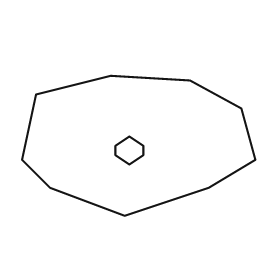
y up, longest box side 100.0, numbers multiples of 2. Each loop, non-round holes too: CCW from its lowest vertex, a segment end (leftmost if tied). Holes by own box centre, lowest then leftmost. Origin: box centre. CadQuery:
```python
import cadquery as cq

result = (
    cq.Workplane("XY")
    .moveTo(-6.0, -30.0)
    .lineTo(30.0, -18.0)
    .lineTo(50.0, -6.0)
    .lineTo(44.0, 16.0)
    .lineTo(22.0, 28.0)
    .lineTo(-12.0, 30.0)
    .lineTo(-44.0, 22.0)
    .lineTo(-50.0, -6.0)
    .lineTo(-38.0, -18.0)
    .close()
    .moveTo(-4.0, -8.0)
    .lineTo(2.0, -4.0)
    .lineTo(2.0, 0.0)
    .lineTo(-4.0, 4.0)
    .lineTo(-10.0, 0.0)
    .lineTo(-10.0, -4.0)
    .close()
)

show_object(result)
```